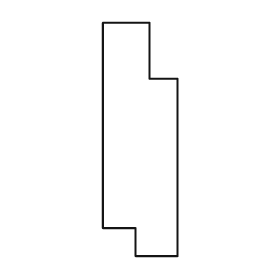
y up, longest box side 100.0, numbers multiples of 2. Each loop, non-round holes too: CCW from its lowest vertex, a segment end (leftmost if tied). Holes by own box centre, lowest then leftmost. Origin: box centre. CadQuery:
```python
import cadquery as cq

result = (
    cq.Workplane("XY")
    .moveTo(-2.0, -50.0)
    .lineTo(16.0, -50.0)
    .lineTo(16.0, 26.0)
    .lineTo(4.0, 26.0)
    .lineTo(4.0, 50.0)
    .lineTo(-16.0, 50.0)
    .lineTo(-16.0, -38.0)
    .lineTo(-2.0, -38.0)
    .close()
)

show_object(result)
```